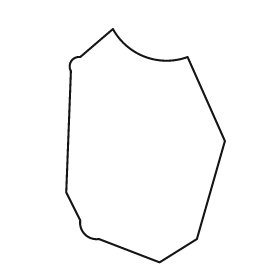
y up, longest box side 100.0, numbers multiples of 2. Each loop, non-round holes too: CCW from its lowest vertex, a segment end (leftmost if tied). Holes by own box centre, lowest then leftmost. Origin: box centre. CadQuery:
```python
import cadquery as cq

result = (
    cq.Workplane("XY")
    .moveTo(6.0, -50.0)
    .lineTo(22.0, -40.0)
    .lineTo(34.0, 2.0)
    .lineTo(18.0, 38.0)
    .threePointArc((0.0, 38.0), (-14.0, 50.0))
    .lineTo(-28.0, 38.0)
    .threePointArc((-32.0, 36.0), (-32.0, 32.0))
    .lineTo(-34.0, -20.0)
    .lineTo(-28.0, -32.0)
    .threePointArc((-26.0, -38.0), (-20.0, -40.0))
    .close()
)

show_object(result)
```